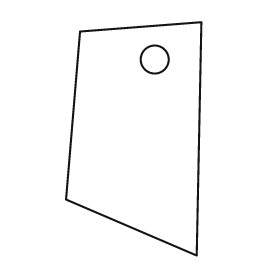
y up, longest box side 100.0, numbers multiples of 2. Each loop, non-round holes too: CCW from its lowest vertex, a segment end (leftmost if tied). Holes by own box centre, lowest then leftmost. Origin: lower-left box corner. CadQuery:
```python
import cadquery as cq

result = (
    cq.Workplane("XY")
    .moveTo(56.0, 0.0)
    .lineTo(58.0, 100.0)
    .lineTo(6.0, 96.0)
    .lineTo(0.0, 24.0)
    .close()
    .moveTo(38.0, 84.0)
    .circle(6.0)
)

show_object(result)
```